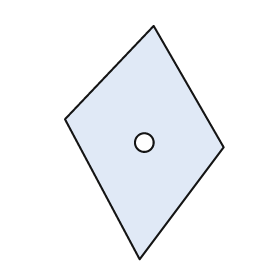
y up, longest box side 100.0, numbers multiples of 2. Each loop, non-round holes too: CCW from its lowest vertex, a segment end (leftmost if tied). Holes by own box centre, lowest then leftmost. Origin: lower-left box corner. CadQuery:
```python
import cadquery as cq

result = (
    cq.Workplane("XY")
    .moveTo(32.0, 0.0)
    .lineTo(68.0, 48.0)
    .lineTo(38.0, 100.0)
    .lineTo(0.0, 60.0)
    .close()
    .moveTo(34.0, 50.0)
    .circle(4.0)
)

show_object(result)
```